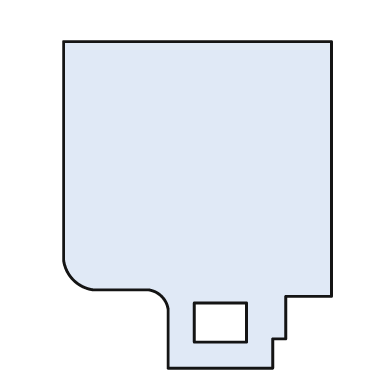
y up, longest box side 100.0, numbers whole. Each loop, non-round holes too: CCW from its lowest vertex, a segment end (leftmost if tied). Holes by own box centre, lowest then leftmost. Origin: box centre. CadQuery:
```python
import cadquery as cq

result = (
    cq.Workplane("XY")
    .moveTo(-9.0, -50.0)
    .lineTo(23.0, -50.0)
    .lineTo(23.0, -41.0)
    .lineTo(27.0, -41.0)
    .lineTo(27.0, -28.0)
    .lineTo(41.0, -28.0)
    .lineTo(41.0, 50.0)
    .lineTo(-41.0, 50.0)
    .lineTo(-41.0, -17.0)
    .threePointArc((-38.0, -23.0), (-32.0, -26.0))
    .lineTo(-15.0, -26.0)
    .threePointArc((-11.0, -28.0), (-9.0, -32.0))
    .close()
    .moveTo(-1.0, -42.0)
    .lineTo(15.0, -42.0)
    .lineTo(15.0, -30.0)
    .lineTo(-1.0, -30.0)
    .close()
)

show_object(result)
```